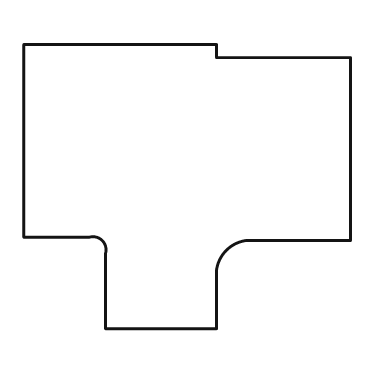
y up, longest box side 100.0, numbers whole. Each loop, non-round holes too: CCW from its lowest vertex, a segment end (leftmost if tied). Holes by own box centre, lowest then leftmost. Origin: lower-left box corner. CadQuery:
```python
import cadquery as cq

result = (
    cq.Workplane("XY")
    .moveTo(25.0, 0.0)
    .lineTo(59.0, 0.0)
    .lineTo(59.0, 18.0)
    .threePointArc((62.0, 24.0), (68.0, 27.0))
    .lineTo(100.0, 27.0)
    .lineTo(100.0, 83.0)
    .lineTo(59.0, 83.0)
    .lineTo(59.0, 87.0)
    .lineTo(0.0, 87.0)
    .lineTo(0.0, 28.0)
    .lineTo(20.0, 28.0)
    .threePointArc((24.0, 27.0), (25.0, 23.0))
    .close()
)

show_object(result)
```